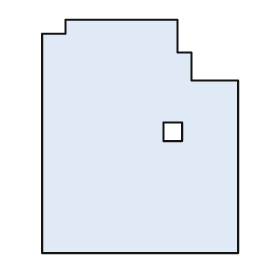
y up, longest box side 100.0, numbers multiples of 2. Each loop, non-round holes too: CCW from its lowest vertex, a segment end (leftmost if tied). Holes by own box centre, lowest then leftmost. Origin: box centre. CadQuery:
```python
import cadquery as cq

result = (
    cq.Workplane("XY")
    .moveTo(-42.0, -50.0)
    .lineTo(42.0, -50.0)
    .lineTo(42.0, 24.0)
    .lineTo(22.0, 24.0)
    .lineTo(22.0, 36.0)
    .lineTo(16.0, 36.0)
    .lineTo(16.0, 50.0)
    .lineTo(-32.0, 50.0)
    .lineTo(-32.0, 44.0)
    .lineTo(-42.0, 44.0)
    .close()
    .moveTo(10.0, -2.0)
    .lineTo(18.0, -2.0)
    .lineTo(18.0, 6.0)
    .lineTo(10.0, 6.0)
    .close()
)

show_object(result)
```